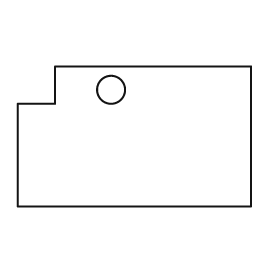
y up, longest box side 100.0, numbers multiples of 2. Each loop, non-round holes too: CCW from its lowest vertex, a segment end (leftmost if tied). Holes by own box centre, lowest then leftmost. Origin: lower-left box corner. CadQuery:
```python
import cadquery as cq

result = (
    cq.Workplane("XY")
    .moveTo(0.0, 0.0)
    .lineTo(100.0, 0.0)
    .lineTo(100.0, 60.0)
    .lineTo(16.0, 60.0)
    .lineTo(16.0, 44.0)
    .lineTo(0.0, 44.0)
    .close()
    .moveTo(40.0, 50.0)
    .circle(6.0)
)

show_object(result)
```